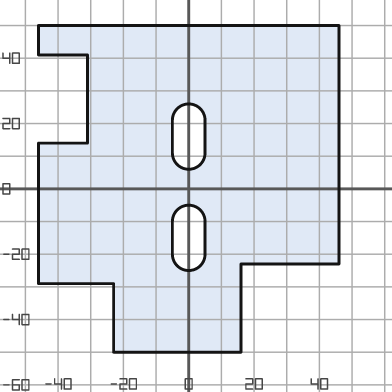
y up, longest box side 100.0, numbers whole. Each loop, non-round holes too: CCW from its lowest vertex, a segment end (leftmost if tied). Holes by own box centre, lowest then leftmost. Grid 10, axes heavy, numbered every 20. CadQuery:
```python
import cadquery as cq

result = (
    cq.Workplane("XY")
    .moveTo(-23.0, -50.0)
    .lineTo(16.0, -50.0)
    .lineTo(16.0, -23.0)
    .lineTo(46.0, -23.0)
    .lineTo(46.0, 50.0)
    .lineTo(-46.0, 50.0)
    .lineTo(-46.0, 41.0)
    .lineTo(-31.0, 41.0)
    .lineTo(-31.0, 14.0)
    .lineTo(-46.0, 14.0)
    .lineTo(-46.0, -29.0)
    .lineTo(-23.0, -29.0)
    .close()
    .moveTo(-5.0, -20.0)
    .threePointArc((0.0, -25.0), (5.0, -20.0))
    .lineTo(5.0, -10.0)
    .threePointArc((0.0, -5.0), (-5.0, -10.0))
    .close()
    .moveTo(-5.0, 11.0)
    .threePointArc((0.0, 6.0), (5.0, 11.0))
    .lineTo(5.0, 21.0)
    .threePointArc((0.0, 26.0), (-5.0, 21.0))
    .close()
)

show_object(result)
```